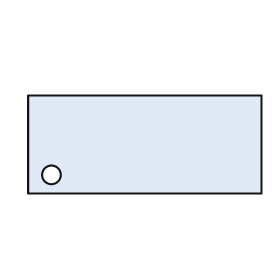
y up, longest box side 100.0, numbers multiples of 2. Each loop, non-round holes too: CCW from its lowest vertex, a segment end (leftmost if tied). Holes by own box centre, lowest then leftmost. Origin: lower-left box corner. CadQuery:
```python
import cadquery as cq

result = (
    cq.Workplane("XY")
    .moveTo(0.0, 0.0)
    .lineTo(100.0, 0.0)
    .lineTo(100.0, 42.0)
    .lineTo(0.0, 42.0)
    .close()
    .moveTo(10.0, 8.0)
    .circle(4.0)
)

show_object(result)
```